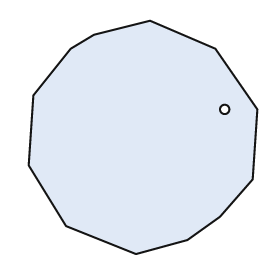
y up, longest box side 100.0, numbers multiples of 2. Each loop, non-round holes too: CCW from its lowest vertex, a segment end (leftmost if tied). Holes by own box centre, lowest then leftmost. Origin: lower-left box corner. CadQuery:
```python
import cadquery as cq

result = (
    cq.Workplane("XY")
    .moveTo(46.0, 0.0)
    .lineTo(68.0, 6.0)
    .lineTo(82.0, 16.0)
    .lineTo(96.0, 32.0)
    .lineTo(98.0, 62.0)
    .lineTo(80.0, 88.0)
    .lineTo(52.0, 100.0)
    .lineTo(28.0, 94.0)
    .lineTo(18.0, 88.0)
    .lineTo(2.0, 68.0)
    .lineTo(0.0, 38.0)
    .lineTo(16.0, 12.0)
    .close()
    .moveTo(84.0, 62.0)
    .circle(2.0)
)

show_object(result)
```